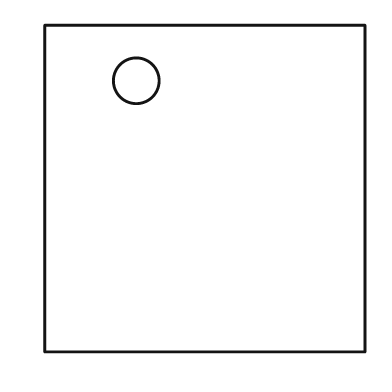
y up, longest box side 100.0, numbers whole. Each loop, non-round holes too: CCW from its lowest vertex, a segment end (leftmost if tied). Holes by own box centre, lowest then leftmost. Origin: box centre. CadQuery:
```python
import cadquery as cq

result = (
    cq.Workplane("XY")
    .moveTo(-49.0, -50.0)
    .lineTo(49.0, -50.0)
    .lineTo(49.0, 50.0)
    .lineTo(-49.0, 50.0)
    .close()
    .moveTo(-21.0, 33.0)
    .circle(7.0)
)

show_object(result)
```